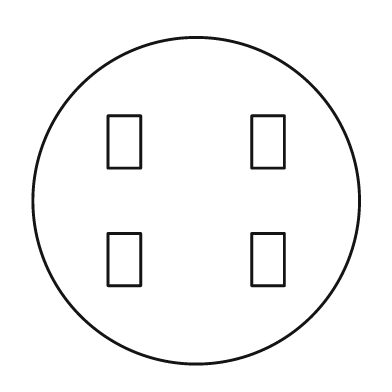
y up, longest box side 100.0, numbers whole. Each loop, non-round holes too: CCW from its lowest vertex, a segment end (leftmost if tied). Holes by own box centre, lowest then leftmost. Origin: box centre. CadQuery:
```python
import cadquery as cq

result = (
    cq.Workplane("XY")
    .moveTo(0.0, 0.0)
    .circle(50.0)
    .moveTo(-27.0, -26.0)
    .lineTo(-17.0, -26.0)
    .lineTo(-17.0, -10.0)
    .lineTo(-27.0, -10.0)
    .close()
    .moveTo(17.0, -26.0)
    .lineTo(27.0, -26.0)
    .lineTo(27.0, -10.0)
    .lineTo(17.0, -10.0)
    .close()
    .moveTo(-27.0, 10.0)
    .lineTo(-17.0, 10.0)
    .lineTo(-17.0, 26.0)
    .lineTo(-27.0, 26.0)
    .close()
    .moveTo(17.0, 10.0)
    .lineTo(27.0, 10.0)
    .lineTo(27.0, 26.0)
    .lineTo(17.0, 26.0)
    .close()
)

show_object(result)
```